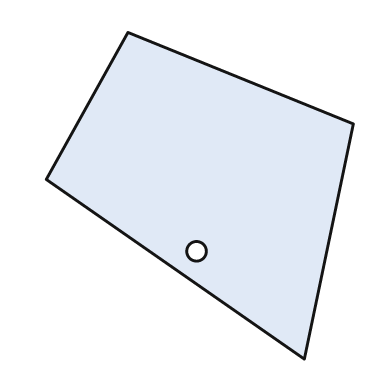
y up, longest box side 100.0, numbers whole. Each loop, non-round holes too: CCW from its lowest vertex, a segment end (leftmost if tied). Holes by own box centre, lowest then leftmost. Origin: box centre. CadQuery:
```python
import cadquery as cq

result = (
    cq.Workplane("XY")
    .moveTo(32.0, -50.0)
    .lineTo(47.0, 22.0)
    .lineTo(-22.0, 50.0)
    .lineTo(-47.0, 5.0)
    .close()
    .moveTo(-1.0, -17.0)
    .circle(3.0)
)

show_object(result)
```